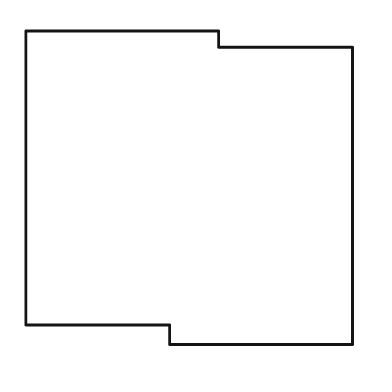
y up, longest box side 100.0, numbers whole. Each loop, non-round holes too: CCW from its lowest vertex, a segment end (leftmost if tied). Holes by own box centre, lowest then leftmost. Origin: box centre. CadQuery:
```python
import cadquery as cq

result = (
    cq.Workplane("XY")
    .moveTo(-6.0, -48.0)
    .lineTo(50.0, -48.0)
    .lineTo(50.0, 43.0)
    .lineTo(9.0, 43.0)
    .lineTo(9.0, 48.0)
    .lineTo(-50.0, 48.0)
    .lineTo(-50.0, -42.0)
    .lineTo(-6.0, -42.0)
    .close()
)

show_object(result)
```